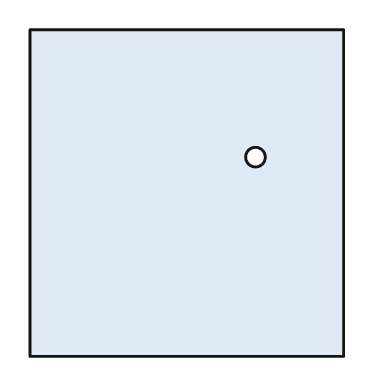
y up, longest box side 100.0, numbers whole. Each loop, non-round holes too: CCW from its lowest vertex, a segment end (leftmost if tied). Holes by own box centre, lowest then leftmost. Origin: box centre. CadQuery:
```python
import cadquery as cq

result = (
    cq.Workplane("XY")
    .moveTo(-48.0, -50.0)
    .lineTo(48.0, -50.0)
    .lineTo(48.0, 50.0)
    .lineTo(-48.0, 50.0)
    .close()
    .moveTo(21.0, 11.0)
    .circle(3.0)
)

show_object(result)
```